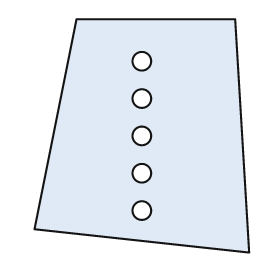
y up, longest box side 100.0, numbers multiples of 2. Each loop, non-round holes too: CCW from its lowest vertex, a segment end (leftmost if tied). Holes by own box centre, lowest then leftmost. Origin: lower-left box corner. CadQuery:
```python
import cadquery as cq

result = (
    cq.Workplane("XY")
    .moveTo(92.0, 0.0)
    .lineTo(86.0, 100.0)
    .lineTo(18.0, 100.0)
    .lineTo(0.0, 10.0)
    .close()
    .moveTo(46.0, 18.0)
    .circle(4.0)
    .moveTo(46.0, 34.0)
    .circle(4.0)
    .moveTo(46.0, 50.0)
    .circle(4.0)
    .moveTo(46.0, 66.0)
    .circle(4.0)
    .moveTo(46.0, 82.0)
    .circle(4.0)
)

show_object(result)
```